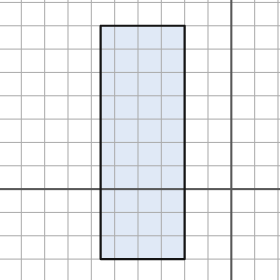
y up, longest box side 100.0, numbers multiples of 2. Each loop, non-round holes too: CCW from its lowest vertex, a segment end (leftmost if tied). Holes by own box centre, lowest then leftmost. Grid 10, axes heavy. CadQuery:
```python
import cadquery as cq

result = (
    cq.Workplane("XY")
    .moveTo(-56.0, -30.0)
    .lineTo(-20.0, -30.0)
    .lineTo(-20.0, 70.0)
    .lineTo(-56.0, 70.0)
    .close()
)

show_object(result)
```